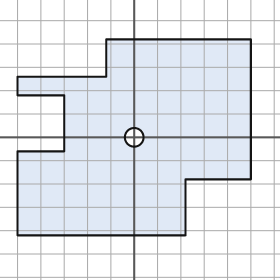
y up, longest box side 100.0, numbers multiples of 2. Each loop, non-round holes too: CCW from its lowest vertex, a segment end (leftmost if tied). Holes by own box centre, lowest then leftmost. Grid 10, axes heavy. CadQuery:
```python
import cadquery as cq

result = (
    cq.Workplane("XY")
    .moveTo(-50.0, -42.0)
    .lineTo(22.0, -42.0)
    .lineTo(22.0, -18.0)
    .lineTo(50.0, -18.0)
    .lineTo(50.0, 42.0)
    .lineTo(-12.0, 42.0)
    .lineTo(-12.0, 26.0)
    .lineTo(-50.0, 26.0)
    .lineTo(-50.0, 18.0)
    .lineTo(-30.0, 18.0)
    .lineTo(-30.0, -6.0)
    .lineTo(-50.0, -6.0)
    .close()
    .moveTo(0.0, 0.0)
    .circle(4.0)
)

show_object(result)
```